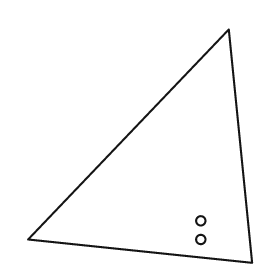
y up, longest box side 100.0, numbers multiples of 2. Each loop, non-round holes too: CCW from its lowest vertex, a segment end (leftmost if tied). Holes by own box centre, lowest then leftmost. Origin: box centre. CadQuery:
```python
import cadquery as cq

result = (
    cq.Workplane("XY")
    .moveTo(48.0, -50.0)
    .lineTo(38.0, 50.0)
    .lineTo(-48.0, -40.0)
    .close()
    .moveTo(26.0, -40.0)
    .circle(2.0)
    .moveTo(26.0, -32.0)
    .circle(2.0)
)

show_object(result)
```